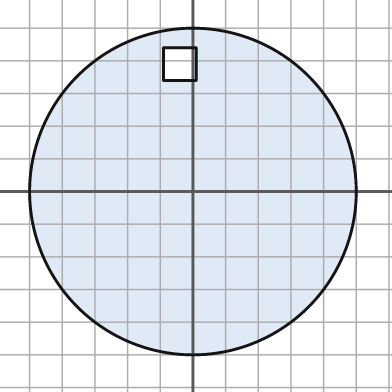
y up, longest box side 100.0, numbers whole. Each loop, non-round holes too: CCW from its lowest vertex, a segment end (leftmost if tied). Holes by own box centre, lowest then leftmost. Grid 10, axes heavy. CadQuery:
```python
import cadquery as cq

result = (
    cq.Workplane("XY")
    .moveTo(0.0, 0.0)
    .circle(50.0)
    .moveTo(-9.0, 34.0)
    .lineTo(1.0, 34.0)
    .lineTo(1.0, 44.0)
    .lineTo(-9.0, 44.0)
    .close()
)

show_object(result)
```